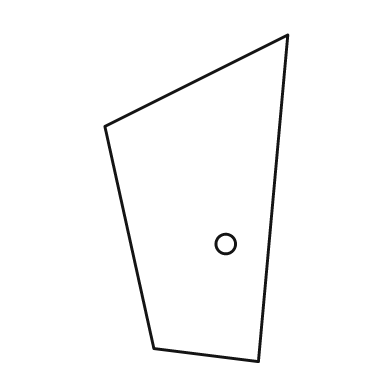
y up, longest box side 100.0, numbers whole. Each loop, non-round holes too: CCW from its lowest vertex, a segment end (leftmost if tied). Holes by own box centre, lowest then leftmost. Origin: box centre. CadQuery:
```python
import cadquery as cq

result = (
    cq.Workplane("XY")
    .moveTo(19.0, -50.0)
    .lineTo(28.0, 50.0)
    .lineTo(-28.0, 22.0)
    .lineTo(-13.0, -46.0)
    .close()
    .moveTo(9.0, -14.0)
    .circle(3.0)
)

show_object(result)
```